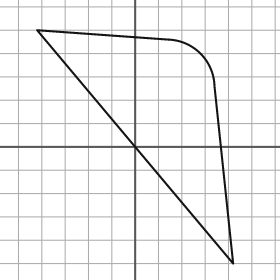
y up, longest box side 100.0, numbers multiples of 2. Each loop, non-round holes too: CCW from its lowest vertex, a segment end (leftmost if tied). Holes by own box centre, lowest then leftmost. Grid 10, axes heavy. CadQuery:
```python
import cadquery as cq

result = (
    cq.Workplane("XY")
    .moveTo(42.0, -50.0)
    .lineTo(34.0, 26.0)
    .threePointArc((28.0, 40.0), (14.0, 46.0))
    .lineTo(-42.0, 50.0)
    .close()
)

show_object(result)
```